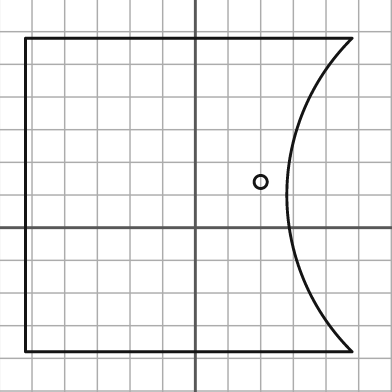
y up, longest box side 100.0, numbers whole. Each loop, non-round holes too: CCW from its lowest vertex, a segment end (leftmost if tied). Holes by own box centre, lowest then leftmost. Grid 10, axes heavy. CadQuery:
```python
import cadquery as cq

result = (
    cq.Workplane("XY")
    .moveTo(-52.0, -38.0)
    .lineTo(48.0, -38.0)
    .threePointArc((28.0, 10.0), (48.0, 58.0))
    .lineTo(-52.0, 58.0)
    .close()
    .moveTo(20.0, 14.0)
    .circle(2.0)
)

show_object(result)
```